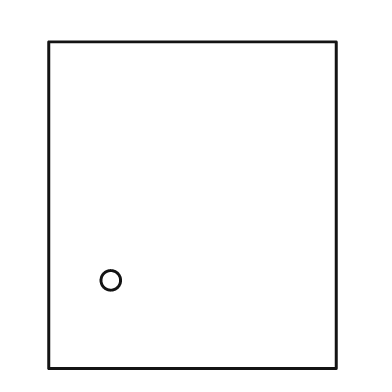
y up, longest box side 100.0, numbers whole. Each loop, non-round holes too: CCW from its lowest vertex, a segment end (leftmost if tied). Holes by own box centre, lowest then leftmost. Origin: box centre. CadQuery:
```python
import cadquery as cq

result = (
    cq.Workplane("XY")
    .moveTo(-44.0, -50.0)
    .lineTo(44.0, -50.0)
    .lineTo(44.0, 50.0)
    .lineTo(-44.0, 50.0)
    .close()
    .moveTo(-25.0, -23.0)
    .circle(3.0)
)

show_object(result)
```